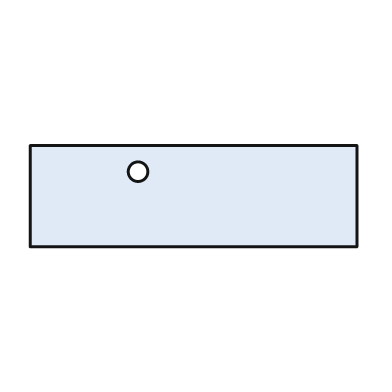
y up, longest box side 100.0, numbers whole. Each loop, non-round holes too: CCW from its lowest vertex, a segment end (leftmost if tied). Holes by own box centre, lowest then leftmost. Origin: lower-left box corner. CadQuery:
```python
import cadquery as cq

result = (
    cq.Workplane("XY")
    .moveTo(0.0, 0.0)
    .lineTo(100.0, 0.0)
    .lineTo(100.0, 31.0)
    .lineTo(0.0, 31.0)
    .close()
    .moveTo(33.0, 23.0)
    .circle(3.0)
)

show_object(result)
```